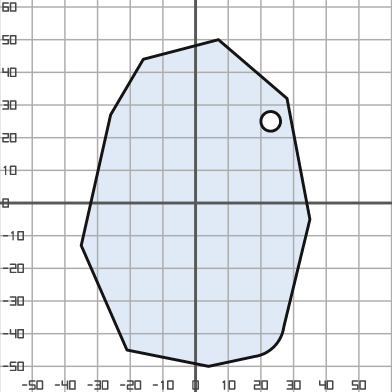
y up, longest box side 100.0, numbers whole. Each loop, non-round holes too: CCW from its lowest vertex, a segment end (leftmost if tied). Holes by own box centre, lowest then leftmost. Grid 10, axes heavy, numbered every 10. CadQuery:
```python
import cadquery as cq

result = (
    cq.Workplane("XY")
    .moveTo(4.0, -50.0)
    .lineTo(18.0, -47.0)
    .threePointArc((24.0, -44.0), (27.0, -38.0))
    .lineTo(35.0, -5.0)
    .lineTo(28.0, 32.0)
    .lineTo(7.0, 50.0)
    .lineTo(-16.0, 44.0)
    .lineTo(-26.0, 27.0)
    .lineTo(-35.0, -13.0)
    .lineTo(-21.0, -45.0)
    .close()
    .moveTo(23.0, 25.0)
    .circle(3.0)
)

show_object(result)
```